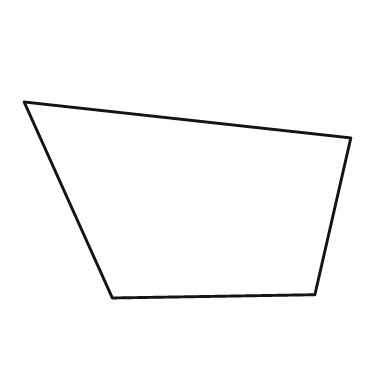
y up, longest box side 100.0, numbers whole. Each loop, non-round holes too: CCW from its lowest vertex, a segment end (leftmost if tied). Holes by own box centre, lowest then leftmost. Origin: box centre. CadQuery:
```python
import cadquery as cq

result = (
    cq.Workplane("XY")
    .moveTo(-23.0, -30.0)
    .lineTo(39.0, -29.0)
    .lineTo(50.0, 19.0)
    .lineTo(-50.0, 30.0)
    .close()
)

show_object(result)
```